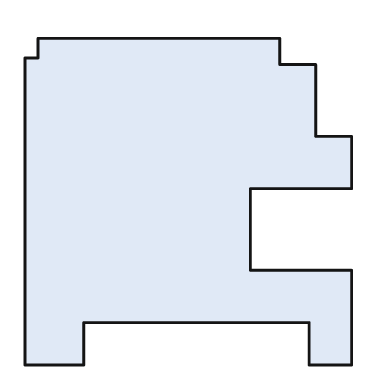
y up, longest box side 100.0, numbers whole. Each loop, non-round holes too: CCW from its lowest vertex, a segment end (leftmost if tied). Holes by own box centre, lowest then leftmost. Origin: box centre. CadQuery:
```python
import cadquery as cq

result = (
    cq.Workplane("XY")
    .moveTo(-50.0, -50.0)
    .lineTo(-32.0, -50.0)
    .lineTo(-32.0, -37.0)
    .lineTo(37.0, -37.0)
    .lineTo(37.0, -50.0)
    .lineTo(50.0, -50.0)
    .lineTo(50.0, -21.0)
    .lineTo(19.0, -21.0)
    .lineTo(19.0, 4.0)
    .lineTo(50.0, 4.0)
    .lineTo(50.0, 20.0)
    .lineTo(39.0, 20.0)
    .lineTo(39.0, 42.0)
    .lineTo(28.0, 42.0)
    .lineTo(28.0, 50.0)
    .lineTo(-46.0, 50.0)
    .lineTo(-46.0, 44.0)
    .lineTo(-50.0, 44.0)
    .close()
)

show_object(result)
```